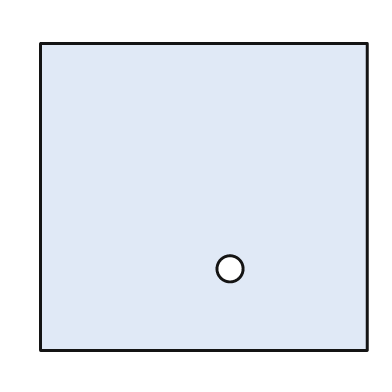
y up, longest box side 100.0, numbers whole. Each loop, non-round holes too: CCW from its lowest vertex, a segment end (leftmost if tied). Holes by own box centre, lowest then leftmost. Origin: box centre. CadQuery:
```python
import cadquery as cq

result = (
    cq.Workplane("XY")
    .moveTo(-50.0, -47.0)
    .lineTo(50.0, -47.0)
    .lineTo(50.0, 47.0)
    .lineTo(-50.0, 47.0)
    .close()
    .moveTo(8.0, -22.0)
    .circle(4.0)
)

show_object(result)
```